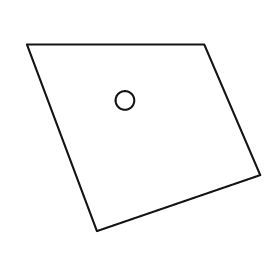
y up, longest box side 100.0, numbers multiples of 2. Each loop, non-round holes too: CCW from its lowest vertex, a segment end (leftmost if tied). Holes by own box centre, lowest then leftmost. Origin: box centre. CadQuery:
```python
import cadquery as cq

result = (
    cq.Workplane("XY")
    .moveTo(-20.0, -40.0)
    .lineTo(50.0, -16.0)
    .lineTo(26.0, 40.0)
    .lineTo(-50.0, 40.0)
    .close()
    .moveTo(-8.0, 16.0)
    .circle(4.0)
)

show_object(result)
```